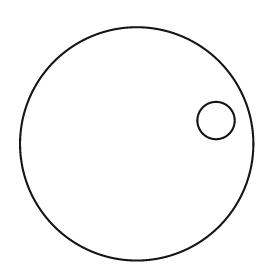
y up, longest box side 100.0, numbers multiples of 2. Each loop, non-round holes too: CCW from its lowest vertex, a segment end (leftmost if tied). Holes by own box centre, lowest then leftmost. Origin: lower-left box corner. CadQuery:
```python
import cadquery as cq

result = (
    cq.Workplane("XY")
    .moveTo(50.0, 50.0)
    .circle(50.0)
    .moveTo(84.0, 60.0)
    .circle(8.0)
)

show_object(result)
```